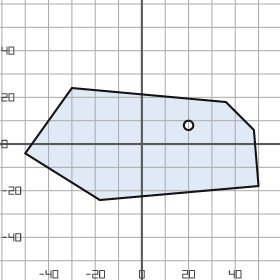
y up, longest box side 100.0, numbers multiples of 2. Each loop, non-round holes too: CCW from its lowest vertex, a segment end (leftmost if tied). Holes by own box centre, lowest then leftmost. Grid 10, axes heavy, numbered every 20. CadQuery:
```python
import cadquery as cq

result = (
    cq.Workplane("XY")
    .moveTo(-18.0, -24.0)
    .lineTo(50.0, -18.0)
    .lineTo(48.0, 6.0)
    .lineTo(36.0, 18.0)
    .lineTo(-30.0, 24.0)
    .lineTo(-50.0, -4.0)
    .close()
    .moveTo(20.0, 8.0)
    .circle(2.0)
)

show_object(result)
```